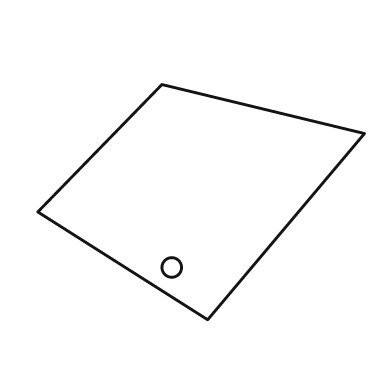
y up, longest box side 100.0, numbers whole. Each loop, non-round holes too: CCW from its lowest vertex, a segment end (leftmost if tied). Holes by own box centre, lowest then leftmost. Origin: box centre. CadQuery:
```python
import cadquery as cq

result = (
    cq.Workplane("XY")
    .moveTo(2.0, -36.0)
    .lineTo(50.0, 21.0)
    .lineTo(-12.0, 36.0)
    .lineTo(-50.0, -3.0)
    .close()
    .moveTo(-9.0, -20.0)
    .circle(3.0)
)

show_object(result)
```